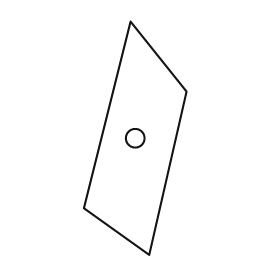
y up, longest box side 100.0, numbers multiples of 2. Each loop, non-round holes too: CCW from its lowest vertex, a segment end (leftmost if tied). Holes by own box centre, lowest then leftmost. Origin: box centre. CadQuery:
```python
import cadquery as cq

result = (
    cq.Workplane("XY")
    .moveTo(6.0, -50.0)
    .lineTo(22.0, 20.0)
    .lineTo(-2.0, 50.0)
    .lineTo(-22.0, -30.0)
    .close()
    .moveTo(0.0, 0.0)
    .circle(4.0)
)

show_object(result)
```